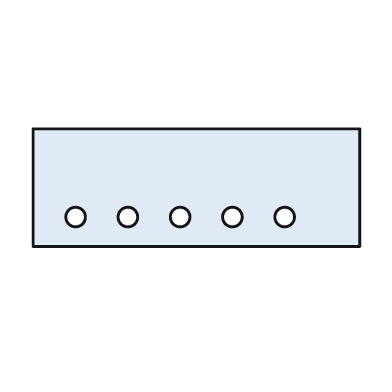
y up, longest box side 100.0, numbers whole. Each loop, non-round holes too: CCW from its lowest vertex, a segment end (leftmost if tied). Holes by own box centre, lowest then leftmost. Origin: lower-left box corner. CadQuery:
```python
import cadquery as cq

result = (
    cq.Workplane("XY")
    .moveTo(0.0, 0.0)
    .lineTo(100.0, 0.0)
    .lineTo(100.0, 36.0)
    .lineTo(0.0, 36.0)
    .close()
    .moveTo(13.0, 9.0)
    .circle(3.0)
    .moveTo(29.0, 9.0)
    .circle(3.0)
    .moveTo(45.0, 9.0)
    .circle(3.0)
    .moveTo(61.0, 9.0)
    .circle(3.0)
    .moveTo(77.0, 9.0)
    .circle(3.0)
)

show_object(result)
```